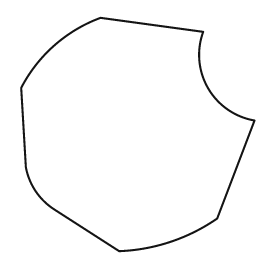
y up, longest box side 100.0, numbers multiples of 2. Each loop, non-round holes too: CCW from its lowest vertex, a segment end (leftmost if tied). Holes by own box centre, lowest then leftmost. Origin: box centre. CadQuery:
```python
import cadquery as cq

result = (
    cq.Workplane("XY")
    .moveTo(-8.0, -50.0)
    .threePointArc((14.0, -46.0), (34.0, -36.0))
    .lineTo(50.0, 6.0)
    .threePointArc((30.0, 20.0), (28.0, 44.0))
    .lineTo(-16.0, 50.0)
    .threePointArc((-36.0, 38.0), (-50.0, 20.0))
    .lineTo(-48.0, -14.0)
    .threePointArc((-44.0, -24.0), (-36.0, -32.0))
    .close()
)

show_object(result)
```